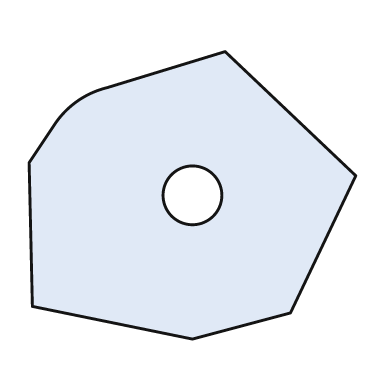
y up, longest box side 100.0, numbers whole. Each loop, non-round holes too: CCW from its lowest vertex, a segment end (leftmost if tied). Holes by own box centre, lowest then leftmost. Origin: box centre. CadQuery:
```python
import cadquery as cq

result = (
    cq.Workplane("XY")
    .moveTo(0.0, -44.0)
    .lineTo(30.0, -36.0)
    .lineTo(50.0, 6.0)
    .lineTo(10.0, 44.0)
    .lineTo(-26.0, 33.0)
    .threePointArc((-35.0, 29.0), (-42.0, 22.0))
    .lineTo(-50.0, 10.0)
    .lineTo(-49.0, -34.0)
    .close()
    .moveTo(0.0, 0.0)
    .circle(9.0)
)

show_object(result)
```